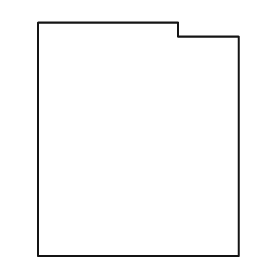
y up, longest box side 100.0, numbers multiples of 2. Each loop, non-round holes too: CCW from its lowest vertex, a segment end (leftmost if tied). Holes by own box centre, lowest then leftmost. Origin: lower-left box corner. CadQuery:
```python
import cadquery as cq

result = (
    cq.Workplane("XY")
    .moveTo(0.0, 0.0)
    .lineTo(86.0, 0.0)
    .lineTo(86.0, 94.0)
    .lineTo(60.0, 94.0)
    .lineTo(60.0, 100.0)
    .lineTo(0.0, 100.0)
    .close()
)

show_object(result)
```